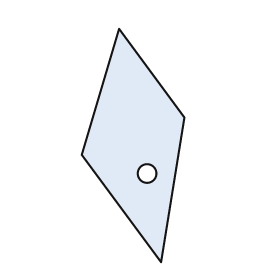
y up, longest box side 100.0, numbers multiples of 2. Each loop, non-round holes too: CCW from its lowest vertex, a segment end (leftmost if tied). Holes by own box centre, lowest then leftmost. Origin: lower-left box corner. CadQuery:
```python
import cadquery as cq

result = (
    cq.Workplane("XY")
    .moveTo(34.0, 0.0)
    .lineTo(44.0, 62.0)
    .lineTo(16.0, 100.0)
    .lineTo(0.0, 46.0)
    .close()
    .moveTo(28.0, 38.0)
    .circle(4.0)
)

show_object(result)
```